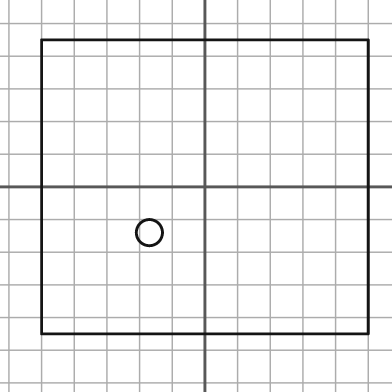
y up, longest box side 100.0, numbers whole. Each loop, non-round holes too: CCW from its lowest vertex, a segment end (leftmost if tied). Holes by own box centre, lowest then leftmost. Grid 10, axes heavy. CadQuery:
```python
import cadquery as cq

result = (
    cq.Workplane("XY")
    .moveTo(-50.0, -45.0)
    .lineTo(50.0, -45.0)
    .lineTo(50.0, 45.0)
    .lineTo(-50.0, 45.0)
    .close()
    .moveTo(-17.0, -14.0)
    .circle(4.0)
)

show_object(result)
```